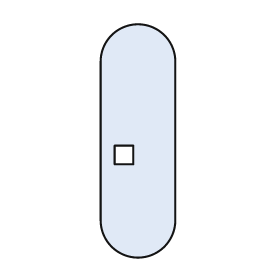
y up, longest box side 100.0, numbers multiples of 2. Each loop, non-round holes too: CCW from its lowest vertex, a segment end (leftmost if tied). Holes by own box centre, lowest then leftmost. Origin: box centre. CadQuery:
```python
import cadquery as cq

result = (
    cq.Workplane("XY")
    .moveTo(-16.0, -34.0)
    .threePointArc((0.0, -50.0), (16.0, -34.0))
    .lineTo(16.0, 34.0)
    .threePointArc((0.0, 50.0), (-16.0, 34.0))
    .close()
    .moveTo(-10.0, -10.0)
    .lineTo(-2.0, -10.0)
    .lineTo(-2.0, -2.0)
    .lineTo(-10.0, -2.0)
    .close()
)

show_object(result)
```